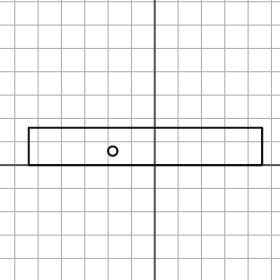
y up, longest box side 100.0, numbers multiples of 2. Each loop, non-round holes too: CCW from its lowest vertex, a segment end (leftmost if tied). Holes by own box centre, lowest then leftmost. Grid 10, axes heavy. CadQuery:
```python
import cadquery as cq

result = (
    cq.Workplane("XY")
    .moveTo(-54.0, 0.0)
    .lineTo(46.0, 0.0)
    .lineTo(46.0, 16.0)
    .lineTo(-54.0, 16.0)
    .close()
    .moveTo(-18.0, 6.0)
    .circle(2.0)
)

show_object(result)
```